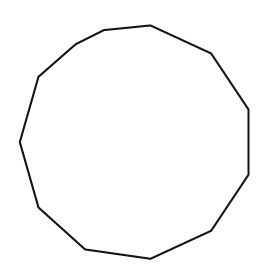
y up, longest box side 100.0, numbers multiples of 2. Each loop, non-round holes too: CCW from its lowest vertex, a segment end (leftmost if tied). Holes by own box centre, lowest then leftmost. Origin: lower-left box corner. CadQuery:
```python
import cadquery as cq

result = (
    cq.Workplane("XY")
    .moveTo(56.0, 0.0)
    .lineTo(82.0, 12.0)
    .lineTo(98.0, 36.0)
    .lineTo(98.0, 64.0)
    .lineTo(82.0, 88.0)
    .lineTo(56.0, 100.0)
    .lineTo(36.0, 98.0)
    .lineTo(24.0, 92.0)
    .lineTo(8.0, 78.0)
    .lineTo(0.0, 50.0)
    .lineTo(8.0, 22.0)
    .lineTo(28.0, 4.0)
    .close()
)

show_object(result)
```